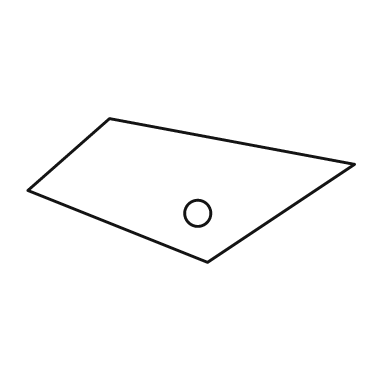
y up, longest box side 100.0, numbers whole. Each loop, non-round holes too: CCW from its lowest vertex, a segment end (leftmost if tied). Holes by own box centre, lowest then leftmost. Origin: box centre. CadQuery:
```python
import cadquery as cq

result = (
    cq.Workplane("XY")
    .moveTo(5.0, -22.0)
    .lineTo(50.0, 8.0)
    .lineTo(-25.0, 22.0)
    .lineTo(-50.0, 0.0)
    .close()
    .moveTo(2.0, -7.0)
    .circle(4.0)
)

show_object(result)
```